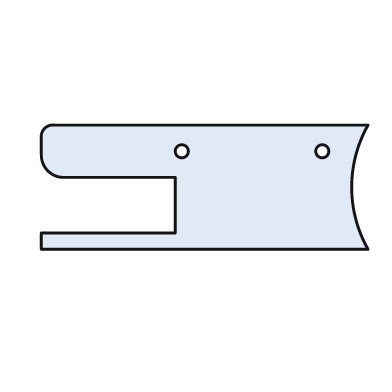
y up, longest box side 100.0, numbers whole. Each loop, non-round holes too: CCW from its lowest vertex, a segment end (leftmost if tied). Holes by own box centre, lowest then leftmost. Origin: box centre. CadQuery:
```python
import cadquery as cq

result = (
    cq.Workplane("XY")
    .moveTo(-50.0, -19.0)
    .lineTo(50.0, -19.0)
    .threePointArc((45.0, 0.0), (50.0, 19.0))
    .lineTo(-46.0, 19.0)
    .threePointArc((-49.0, 18.0), (-50.0, 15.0))
    .lineTo(-50.0, 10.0)
    .threePointArc((-48.0, 5.0), (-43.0, 3.0))
    .lineTo(-9.0, 3.0)
    .lineTo(-9.0, -14.0)
    .lineTo(-50.0, -14.0)
    .close()
    .moveTo(-7.0, 11.0)
    .circle(2.0)
    .moveTo(36.0, 11.0)
    .circle(2.0)
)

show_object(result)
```